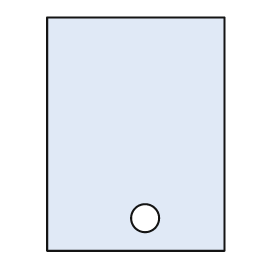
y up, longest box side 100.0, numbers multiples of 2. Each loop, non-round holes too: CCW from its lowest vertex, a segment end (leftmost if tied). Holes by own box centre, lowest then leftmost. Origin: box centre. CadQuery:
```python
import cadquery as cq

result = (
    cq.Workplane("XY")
    .moveTo(-38.0, -50.0)
    .lineTo(38.0, -50.0)
    .lineTo(38.0, 50.0)
    .lineTo(-38.0, 50.0)
    .close()
    .moveTo(4.0, -36.0)
    .circle(6.0)
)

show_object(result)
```